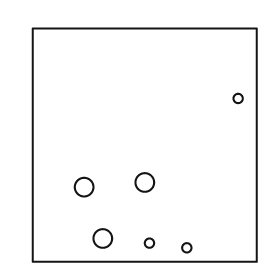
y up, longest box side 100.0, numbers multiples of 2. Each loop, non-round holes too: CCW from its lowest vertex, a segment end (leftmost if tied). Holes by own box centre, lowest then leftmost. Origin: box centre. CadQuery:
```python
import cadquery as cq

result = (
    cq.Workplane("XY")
    .moveTo(-48.0, -50.0)
    .lineTo(48.0, -50.0)
    .lineTo(48.0, 50.0)
    .lineTo(-48.0, 50.0)
    .close()
    .moveTo(18.0, -44.0)
    .circle(2.0)
    .moveTo(2.0, -42.0)
    .circle(2.0)
    .moveTo(-18.0, -40.0)
    .circle(4.0)
    .moveTo(-26.0, -18.0)
    .circle(4.0)
    .moveTo(0.0, -16.0)
    .circle(4.0)
    .moveTo(40.0, 20.0)
    .circle(2.0)
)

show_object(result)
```